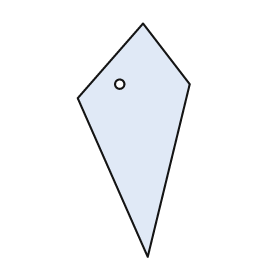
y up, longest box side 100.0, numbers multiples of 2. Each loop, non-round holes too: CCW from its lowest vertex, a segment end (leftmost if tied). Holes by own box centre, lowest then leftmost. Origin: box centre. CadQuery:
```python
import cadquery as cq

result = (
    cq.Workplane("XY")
    .moveTo(6.0, -50.0)
    .lineTo(24.0, 24.0)
    .lineTo(4.0, 50.0)
    .lineTo(-24.0, 18.0)
    .close()
    .moveTo(-6.0, 24.0)
    .circle(2.0)
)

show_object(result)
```